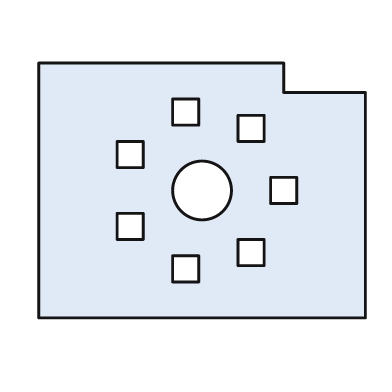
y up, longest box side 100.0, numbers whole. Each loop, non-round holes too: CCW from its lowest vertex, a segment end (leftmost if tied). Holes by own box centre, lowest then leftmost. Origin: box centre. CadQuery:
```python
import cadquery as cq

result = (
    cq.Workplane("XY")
    .moveTo(-50.0, -39.0)
    .lineTo(50.0, -39.0)
    .lineTo(50.0, 30.0)
    .lineTo(25.0, 30.0)
    .lineTo(25.0, 39.0)
    .lineTo(-50.0, 39.0)
    .close()
    .moveTo(-9.0, -28.0)
    .lineTo(-1.0, -28.0)
    .lineTo(-1.0, -20.0)
    .lineTo(-9.0, -20.0)
    .close()
    .moveTo(11.0, -23.0)
    .lineTo(19.0, -23.0)
    .lineTo(19.0, -15.0)
    .lineTo(11.0, -15.0)
    .close()
    .moveTo(-26.0, -15.0)
    .lineTo(-18.0, -15.0)
    .lineTo(-18.0, -7.0)
    .lineTo(-26.0, -7.0)
    .close()
    .moveTo(0.0, 0.0)
    .circle(9.0)
    .moveTo(21.0, -4.0)
    .lineTo(29.0, -4.0)
    .lineTo(29.0, 4.0)
    .lineTo(21.0, 4.0)
    .close()
    .moveTo(-26.0, 7.0)
    .lineTo(-18.0, 7.0)
    .lineTo(-18.0, 15.0)
    .lineTo(-26.0, 15.0)
    .close()
    .moveTo(11.0, 15.0)
    .lineTo(19.0, 15.0)
    .lineTo(19.0, 23.0)
    .lineTo(11.0, 23.0)
    .close()
    .moveTo(-9.0, 20.0)
    .lineTo(-1.0, 20.0)
    .lineTo(-1.0, 28.0)
    .lineTo(-9.0, 28.0)
    .close()
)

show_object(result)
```